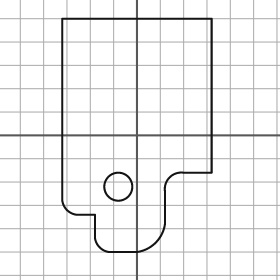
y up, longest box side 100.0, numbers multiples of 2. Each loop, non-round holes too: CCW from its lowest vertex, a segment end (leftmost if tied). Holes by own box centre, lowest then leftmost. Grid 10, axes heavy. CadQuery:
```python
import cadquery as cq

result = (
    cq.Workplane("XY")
    .moveTo(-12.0, -50.0)
    .lineTo(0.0, -50.0)
    .threePointArc((8.0, -46.0), (12.0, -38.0))
    .lineTo(12.0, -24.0)
    .threePointArc((14.0, -18.0), (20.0, -16.0))
    .lineTo(32.0, -16.0)
    .lineTo(32.0, 50.0)
    .lineTo(-32.0, 50.0)
    .lineTo(-32.0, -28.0)
    .threePointArc((-30.0, -32.0), (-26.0, -34.0))
    .lineTo(-18.0, -34.0)
    .lineTo(-18.0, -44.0)
    .threePointArc((-16.0, -48.0), (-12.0, -50.0))
    .close()
    .moveTo(-8.0, -22.0)
    .circle(6.0)
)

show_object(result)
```